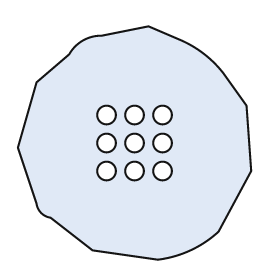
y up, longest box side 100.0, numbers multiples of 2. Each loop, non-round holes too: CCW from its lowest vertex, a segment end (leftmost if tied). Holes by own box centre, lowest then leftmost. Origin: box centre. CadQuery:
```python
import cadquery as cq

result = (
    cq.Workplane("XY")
    .moveTo(10.0, -50.0)
    .threePointArc((24.0, -46.0), (36.0, -38.0))
    .lineTo(50.0, -12.0)
    .lineTo(48.0, 16.0)
    .lineTo(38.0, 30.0)
    .threePointArc((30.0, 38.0), (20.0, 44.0))
    .lineTo(6.0, 50.0)
    .lineTo(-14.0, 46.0)
    .threePointArc((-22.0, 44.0), (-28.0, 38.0))
    .lineTo(-42.0, 26.0)
    .lineTo(-50.0, -2.0)
    .lineTo(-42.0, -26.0)
    .threePointArc((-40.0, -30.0), (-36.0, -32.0))
    .lineTo(-18.0, -46.0)
    .close()
    .moveTo(-12.0, -12.0)
    .circle(4.0)
    .moveTo(0.0, -12.0)
    .circle(4.0)
    .moveTo(12.0, -12.0)
    .circle(4.0)
    .moveTo(-12.0, 0.0)
    .circle(4.0)
    .moveTo(0.0, 0.0)
    .circle(4.0)
    .moveTo(12.0, 0.0)
    .circle(4.0)
    .moveTo(-12.0, 12.0)
    .circle(4.0)
    .moveTo(0.0, 12.0)
    .circle(4.0)
    .moveTo(12.0, 12.0)
    .circle(4.0)
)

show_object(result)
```